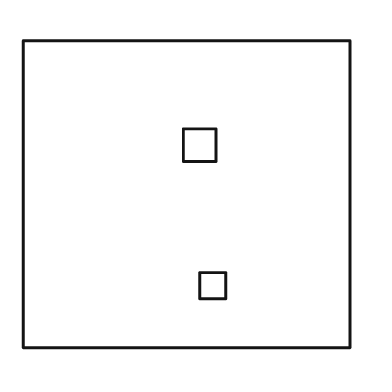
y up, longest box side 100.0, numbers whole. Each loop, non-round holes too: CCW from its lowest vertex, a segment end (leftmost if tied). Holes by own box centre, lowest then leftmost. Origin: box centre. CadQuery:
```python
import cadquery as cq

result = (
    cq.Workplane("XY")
    .moveTo(-50.0, -47.0)
    .lineTo(50.0, -47.0)
    .lineTo(50.0, 47.0)
    .lineTo(-50.0, 47.0)
    .close()
    .moveTo(4.0, -32.0)
    .lineTo(12.0, -32.0)
    .lineTo(12.0, -24.0)
    .lineTo(4.0, -24.0)
    .close()
    .moveTo(-1.0, 10.0)
    .lineTo(9.0, 10.0)
    .lineTo(9.0, 20.0)
    .lineTo(-1.0, 20.0)
    .close()
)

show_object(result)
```